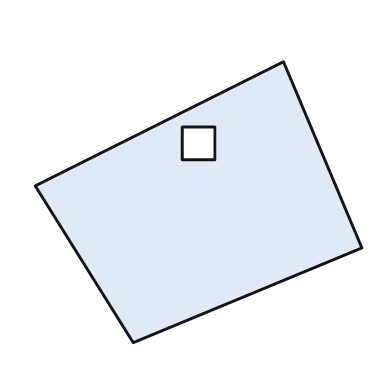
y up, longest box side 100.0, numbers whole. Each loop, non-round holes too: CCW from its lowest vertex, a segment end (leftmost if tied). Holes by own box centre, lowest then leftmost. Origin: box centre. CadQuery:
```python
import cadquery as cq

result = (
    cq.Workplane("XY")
    .moveTo(-20.0, -43.0)
    .lineTo(50.0, -14.0)
    .lineTo(26.0, 43.0)
    .lineTo(-50.0, 5.0)
    .close()
    .moveTo(-5.0, 13.0)
    .lineTo(5.0, 13.0)
    .lineTo(5.0, 23.0)
    .lineTo(-5.0, 23.0)
    .close()
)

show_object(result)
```